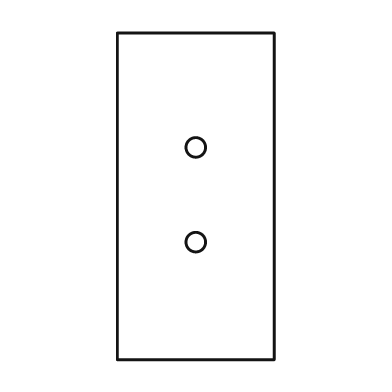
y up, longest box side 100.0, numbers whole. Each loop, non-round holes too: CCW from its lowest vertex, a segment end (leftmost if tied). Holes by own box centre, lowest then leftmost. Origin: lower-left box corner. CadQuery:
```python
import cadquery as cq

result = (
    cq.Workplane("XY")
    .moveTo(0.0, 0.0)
    .lineTo(48.0, 0.0)
    .lineTo(48.0, 100.0)
    .lineTo(0.0, 100.0)
    .close()
    .moveTo(24.0, 36.0)
    .circle(3.0)
    .moveTo(24.0, 65.0)
    .circle(3.0)
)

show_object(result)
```